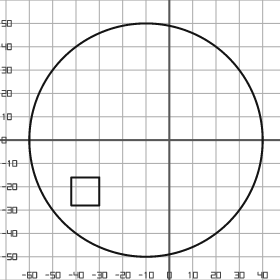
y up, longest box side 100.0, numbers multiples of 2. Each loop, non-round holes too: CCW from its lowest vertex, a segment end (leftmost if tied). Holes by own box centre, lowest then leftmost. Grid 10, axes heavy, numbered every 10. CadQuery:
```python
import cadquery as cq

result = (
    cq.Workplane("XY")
    .moveTo(-10.0, 0.0)
    .circle(50.0)
    .moveTo(-42.0, -28.0)
    .lineTo(-30.0, -28.0)
    .lineTo(-30.0, -16.0)
    .lineTo(-42.0, -16.0)
    .close()
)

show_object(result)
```